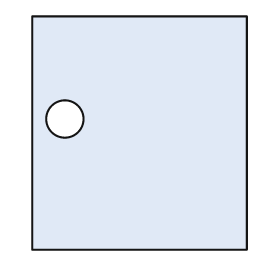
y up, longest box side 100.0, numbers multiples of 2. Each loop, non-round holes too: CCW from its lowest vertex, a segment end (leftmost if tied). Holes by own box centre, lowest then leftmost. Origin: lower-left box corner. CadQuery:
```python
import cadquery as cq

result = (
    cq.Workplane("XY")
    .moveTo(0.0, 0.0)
    .lineTo(92.0, 0.0)
    .lineTo(92.0, 100.0)
    .lineTo(0.0, 100.0)
    .close()
    .moveTo(14.0, 56.0)
    .circle(8.0)
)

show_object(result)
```